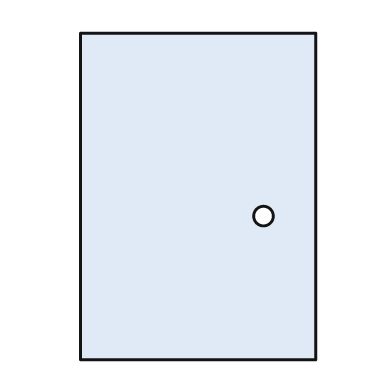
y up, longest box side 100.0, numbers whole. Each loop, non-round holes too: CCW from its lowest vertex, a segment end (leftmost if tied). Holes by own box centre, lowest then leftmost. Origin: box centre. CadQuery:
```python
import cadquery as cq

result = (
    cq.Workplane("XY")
    .moveTo(-36.0, -50.0)
    .lineTo(36.0, -50.0)
    .lineTo(36.0, 50.0)
    .lineTo(-36.0, 50.0)
    .close()
    .moveTo(20.0, -6.0)
    .circle(3.0)
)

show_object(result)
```